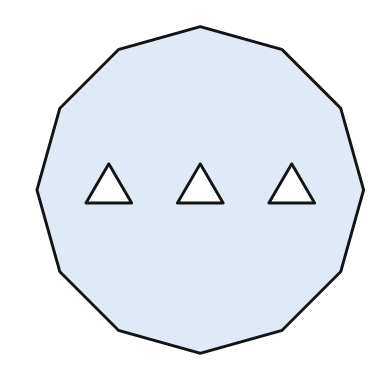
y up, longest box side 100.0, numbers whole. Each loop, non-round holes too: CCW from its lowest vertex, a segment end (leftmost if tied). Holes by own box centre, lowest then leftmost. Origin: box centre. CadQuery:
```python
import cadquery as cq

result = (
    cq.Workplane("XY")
    .moveTo(0.0, -50.0)
    .lineTo(25.0, -43.0)
    .lineTo(43.0, -25.0)
    .lineTo(50.0, 0.0)
    .lineTo(43.0, 25.0)
    .lineTo(25.0, 43.0)
    .lineTo(0.0, 50.0)
    .lineTo(-25.0, 43.0)
    .lineTo(-43.0, 25.0)
    .lineTo(-50.0, 0.0)
    .lineTo(-43.0, -25.0)
    .lineTo(-25.0, -43.0)
    .close()
    .moveTo(-35.0, -4.0)
    .lineTo(-21.0, -4.0)
    .lineTo(-28.0, 8.0)
    .close()
    .moveTo(-7.0, -4.0)
    .lineTo(7.0, -4.0)
    .lineTo(0.0, 8.0)
    .close()
    .moveTo(21.0, -4.0)
    .lineTo(35.0, -4.0)
    .lineTo(28.0, 8.0)
    .close()
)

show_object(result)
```